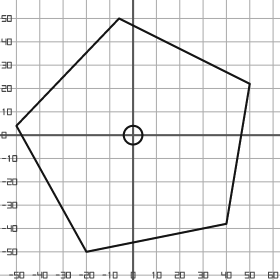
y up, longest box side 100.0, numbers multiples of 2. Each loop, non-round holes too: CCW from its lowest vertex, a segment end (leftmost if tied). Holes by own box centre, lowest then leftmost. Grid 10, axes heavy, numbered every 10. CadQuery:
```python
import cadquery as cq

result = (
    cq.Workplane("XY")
    .moveTo(-20.0, -50.0)
    .lineTo(40.0, -38.0)
    .lineTo(50.0, 22.0)
    .lineTo(-6.0, 50.0)
    .lineTo(-50.0, 4.0)
    .close()
    .moveTo(0.0, 0.0)
    .circle(4.0)
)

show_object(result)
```